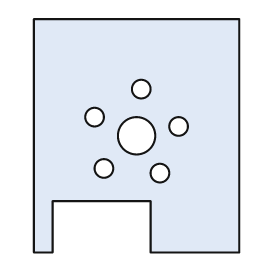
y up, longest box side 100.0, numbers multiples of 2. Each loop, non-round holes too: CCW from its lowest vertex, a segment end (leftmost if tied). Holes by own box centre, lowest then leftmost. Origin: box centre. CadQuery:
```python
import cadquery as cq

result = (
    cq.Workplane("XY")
    .moveTo(-44.0, -50.0)
    .lineTo(-36.0, -50.0)
    .lineTo(-36.0, -28.0)
    .lineTo(6.0, -28.0)
    .lineTo(6.0, -50.0)
    .lineTo(44.0, -50.0)
    .lineTo(44.0, 50.0)
    .lineTo(-44.0, 50.0)
    .close()
    .moveTo(10.0, -16.0)
    .circle(4.0)
    .moveTo(-14.0, -14.0)
    .circle(4.0)
    .moveTo(0.0, 0.0)
    .circle(8.0)
    .moveTo(18.0, 4.0)
    .circle(4.0)
    .moveTo(-18.0, 8.0)
    .circle(4.0)
    .moveTo(2.0, 20.0)
    .circle(4.0)
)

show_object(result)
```